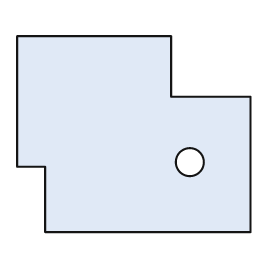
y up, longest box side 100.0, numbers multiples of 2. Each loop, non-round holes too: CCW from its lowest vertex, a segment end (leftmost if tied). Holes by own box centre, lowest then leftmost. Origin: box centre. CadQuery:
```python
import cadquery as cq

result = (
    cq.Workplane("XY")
    .moveTo(-38.0, -42.0)
    .lineTo(50.0, -42.0)
    .lineTo(50.0, 16.0)
    .lineTo(16.0, 16.0)
    .lineTo(16.0, 42.0)
    .lineTo(-50.0, 42.0)
    .lineTo(-50.0, -14.0)
    .lineTo(-38.0, -14.0)
    .close()
    .moveTo(24.0, -12.0)
    .circle(6.0)
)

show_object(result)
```